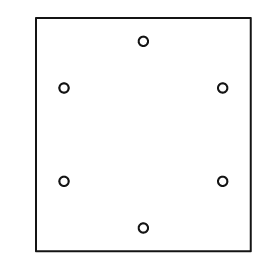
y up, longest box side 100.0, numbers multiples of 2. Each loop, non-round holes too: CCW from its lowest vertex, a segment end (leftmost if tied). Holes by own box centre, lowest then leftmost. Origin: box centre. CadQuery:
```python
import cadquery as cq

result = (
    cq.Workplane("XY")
    .moveTo(-46.0, -50.0)
    .lineTo(46.0, -50.0)
    .lineTo(46.0, 50.0)
    .lineTo(-46.0, 50.0)
    .close()
    .moveTo(0.0, -40.0)
    .circle(2.0)
    .moveTo(-34.0, -20.0)
    .circle(2.0)
    .moveTo(34.0, -20.0)
    .circle(2.0)
    .moveTo(-34.0, 20.0)
    .circle(2.0)
    .moveTo(34.0, 20.0)
    .circle(2.0)
    .moveTo(0.0, 40.0)
    .circle(2.0)
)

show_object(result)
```